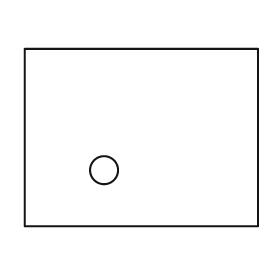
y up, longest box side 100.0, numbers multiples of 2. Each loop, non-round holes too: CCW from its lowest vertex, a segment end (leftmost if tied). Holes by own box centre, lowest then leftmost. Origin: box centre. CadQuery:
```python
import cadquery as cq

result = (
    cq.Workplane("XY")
    .moveTo(-50.0, -38.0)
    .lineTo(50.0, -38.0)
    .lineTo(50.0, 38.0)
    .lineTo(-50.0, 38.0)
    .close()
    .moveTo(-16.0, -14.0)
    .circle(6.0)
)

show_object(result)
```